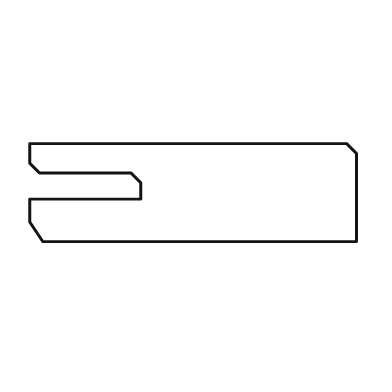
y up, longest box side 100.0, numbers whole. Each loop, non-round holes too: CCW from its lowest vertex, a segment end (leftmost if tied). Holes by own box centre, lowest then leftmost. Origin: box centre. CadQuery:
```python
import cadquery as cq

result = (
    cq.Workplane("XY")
    .moveTo(-46.0, -15.0)
    .lineTo(50.0, -15.0)
    .lineTo(50.0, 12.0)
    .lineTo(47.0, 15.0)
    .lineTo(-50.0, 15.0)
    .lineTo(-50.0, 9.0)
    .lineTo(-47.0, 6.0)
    .lineTo(-19.0, 6.0)
    .lineTo(-16.0, 3.0)
    .lineTo(-16.0, -2.0)
    .lineTo(-50.0, -2.0)
    .lineTo(-50.0, -9.0)
    .close()
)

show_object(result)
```